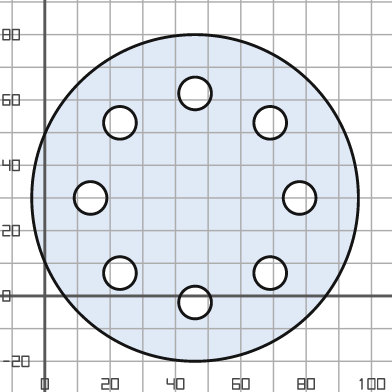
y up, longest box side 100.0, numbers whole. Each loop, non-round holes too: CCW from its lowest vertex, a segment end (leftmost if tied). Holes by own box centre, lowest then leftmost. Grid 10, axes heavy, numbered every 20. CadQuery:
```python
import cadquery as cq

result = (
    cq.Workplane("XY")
    .moveTo(46.0, 30.0)
    .circle(50.0)
    .moveTo(46.0, -2.0)
    .circle(5.0)
    .moveTo(23.0, 7.0)
    .circle(5.0)
    .moveTo(69.0, 7.0)
    .circle(5.0)
    .moveTo(14.0, 30.0)
    .circle(5.0)
    .moveTo(78.0, 30.0)
    .circle(5.0)
    .moveTo(23.0, 53.0)
    .circle(5.0)
    .moveTo(69.0, 53.0)
    .circle(5.0)
    .moveTo(46.0, 62.0)
    .circle(5.0)
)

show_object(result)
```